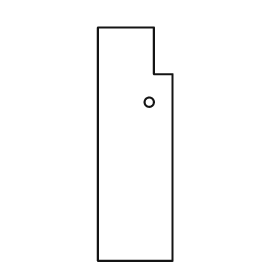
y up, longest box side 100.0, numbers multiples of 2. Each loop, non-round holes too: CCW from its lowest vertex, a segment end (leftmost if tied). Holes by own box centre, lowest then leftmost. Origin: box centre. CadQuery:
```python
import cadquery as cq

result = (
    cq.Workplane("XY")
    .moveTo(-16.0, -50.0)
    .lineTo(16.0, -50.0)
    .lineTo(16.0, 30.0)
    .lineTo(8.0, 30.0)
    .lineTo(8.0, 50.0)
    .lineTo(-16.0, 50.0)
    .close()
    .moveTo(6.0, 18.0)
    .circle(2.0)
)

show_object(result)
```